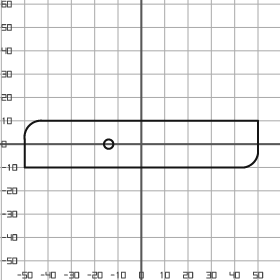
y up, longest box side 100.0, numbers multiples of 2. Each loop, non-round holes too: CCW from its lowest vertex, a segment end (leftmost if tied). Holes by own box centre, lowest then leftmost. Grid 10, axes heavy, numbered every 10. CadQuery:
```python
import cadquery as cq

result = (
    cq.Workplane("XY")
    .moveTo(-50.0, -10.0)
    .lineTo(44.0, -10.0)
    .threePointArc((48.0, -8.0), (50.0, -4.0))
    .lineTo(50.0, 10.0)
    .lineTo(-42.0, 10.0)
    .threePointArc((-48.0, 8.0), (-50.0, 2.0))
    .close()
    .moveTo(-14.0, 0.0)
    .circle(2.0)
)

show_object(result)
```